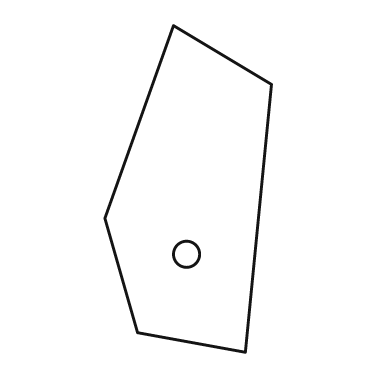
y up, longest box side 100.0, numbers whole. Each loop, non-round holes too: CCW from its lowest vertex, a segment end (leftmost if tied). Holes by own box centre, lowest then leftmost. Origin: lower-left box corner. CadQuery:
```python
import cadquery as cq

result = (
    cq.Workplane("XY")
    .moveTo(43.0, 0.0)
    .lineTo(51.0, 82.0)
    .lineTo(21.0, 100.0)
    .lineTo(0.0, 41.0)
    .lineTo(10.0, 6.0)
    .close()
    .moveTo(25.0, 30.0)
    .circle(4.0)
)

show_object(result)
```